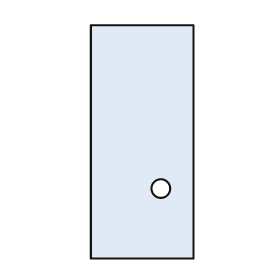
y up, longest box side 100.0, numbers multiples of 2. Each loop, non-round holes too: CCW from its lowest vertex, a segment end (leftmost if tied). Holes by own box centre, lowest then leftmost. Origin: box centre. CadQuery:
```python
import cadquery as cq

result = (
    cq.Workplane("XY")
    .moveTo(-22.0, -50.0)
    .lineTo(22.0, -50.0)
    .lineTo(22.0, 50.0)
    .lineTo(-22.0, 50.0)
    .close()
    .moveTo(8.0, -20.0)
    .circle(4.0)
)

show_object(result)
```